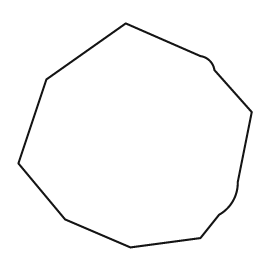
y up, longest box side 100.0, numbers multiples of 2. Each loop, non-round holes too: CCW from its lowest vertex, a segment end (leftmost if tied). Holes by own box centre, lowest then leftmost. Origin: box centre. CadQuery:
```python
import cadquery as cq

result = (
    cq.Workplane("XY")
    .moveTo(-2.0, -48.0)
    .lineTo(28.0, -44.0)
    .lineTo(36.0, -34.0)
    .threePointArc((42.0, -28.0), (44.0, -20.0))
    .lineTo(50.0, 10.0)
    .lineTo(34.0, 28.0)
    .threePointArc((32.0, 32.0), (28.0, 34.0))
    .lineTo(-4.0, 48.0)
    .lineTo(-38.0, 24.0)
    .lineTo(-50.0, -12.0)
    .lineTo(-30.0, -36.0)
    .close()
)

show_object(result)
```